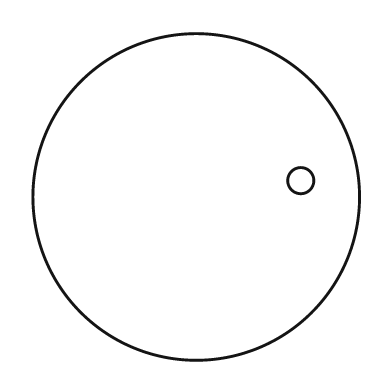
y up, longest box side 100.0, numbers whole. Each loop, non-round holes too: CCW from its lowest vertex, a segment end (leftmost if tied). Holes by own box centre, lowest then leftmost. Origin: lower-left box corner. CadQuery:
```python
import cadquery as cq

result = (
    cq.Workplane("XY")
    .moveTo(50.0, 50.0)
    .circle(50.0)
    .moveTo(82.0, 55.0)
    .circle(4.0)
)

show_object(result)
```